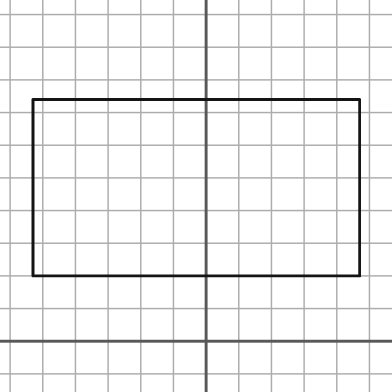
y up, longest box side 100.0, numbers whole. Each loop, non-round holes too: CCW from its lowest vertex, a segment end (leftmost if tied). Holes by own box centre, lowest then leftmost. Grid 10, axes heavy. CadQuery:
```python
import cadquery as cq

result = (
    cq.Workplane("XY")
    .moveTo(-53.0, 20.0)
    .lineTo(47.0, 20.0)
    .lineTo(47.0, 74.0)
    .lineTo(-53.0, 74.0)
    .close()
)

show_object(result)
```